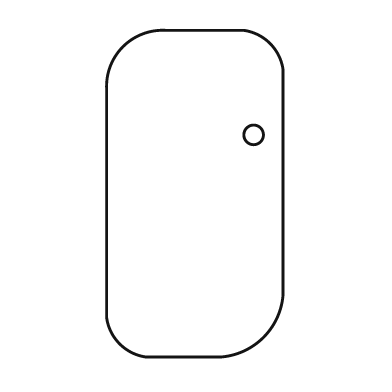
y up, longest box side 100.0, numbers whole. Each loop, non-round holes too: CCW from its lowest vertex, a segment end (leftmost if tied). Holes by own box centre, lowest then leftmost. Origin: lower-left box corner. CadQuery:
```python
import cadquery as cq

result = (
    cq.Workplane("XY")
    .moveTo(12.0, 0.0)
    .lineTo(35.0, 0.0)
    .threePointArc((48.0, 6.0), (54.0, 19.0))
    .lineTo(54.0, 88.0)
    .threePointArc((50.0, 96.0), (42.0, 100.0))
    .lineTo(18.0, 100.0)
    .threePointArc((5.0, 95.0), (0.0, 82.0))
    .lineTo(0.0, 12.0)
    .threePointArc((4.0, 4.0), (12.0, 0.0))
    .close()
    .moveTo(45.0, 68.0)
    .circle(3.0)
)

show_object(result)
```